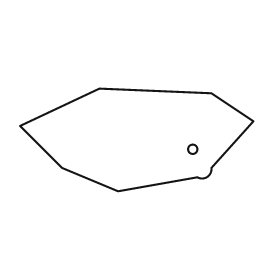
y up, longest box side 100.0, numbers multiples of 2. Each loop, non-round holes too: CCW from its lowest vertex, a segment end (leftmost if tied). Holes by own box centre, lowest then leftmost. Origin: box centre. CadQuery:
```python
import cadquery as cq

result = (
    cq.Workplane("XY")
    .moveTo(-8.0, -22.0)
    .lineTo(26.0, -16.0)
    .threePointArc((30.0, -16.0), (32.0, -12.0))
    .lineTo(50.0, 8.0)
    .lineTo(32.0, 20.0)
    .lineTo(-16.0, 22.0)
    .lineTo(-50.0, 6.0)
    .lineTo(-32.0, -12.0)
    .close()
    .moveTo(24.0, -4.0)
    .circle(2.0)
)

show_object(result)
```